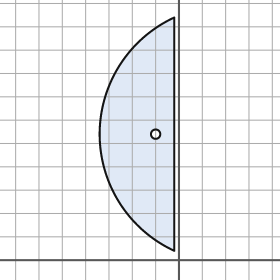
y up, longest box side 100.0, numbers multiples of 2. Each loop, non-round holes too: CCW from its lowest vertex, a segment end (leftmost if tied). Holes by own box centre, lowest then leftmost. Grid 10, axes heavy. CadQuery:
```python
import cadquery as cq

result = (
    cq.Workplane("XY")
    .moveTo(-2.0, 4.0)
    .lineTo(-2.0, 104.0)
    .threePointArc((-34.0, 54.0), (-2.0, 4.0))
    .close()
    .moveTo(-10.0, 54.0)
    .circle(2.0)
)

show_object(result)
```